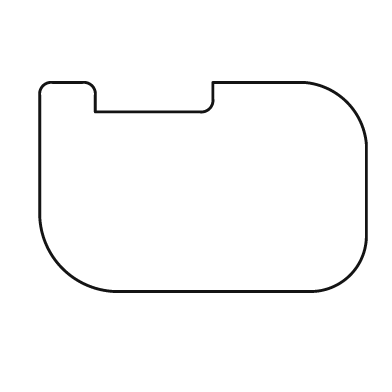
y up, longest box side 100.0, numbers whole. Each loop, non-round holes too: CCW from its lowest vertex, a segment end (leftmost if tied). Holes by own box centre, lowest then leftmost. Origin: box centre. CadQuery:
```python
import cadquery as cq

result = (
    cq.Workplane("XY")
    .moveTo(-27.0, -32.0)
    .lineTo(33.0, -32.0)
    .threePointArc((45.0, -27.0), (50.0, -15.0))
    .lineTo(50.0, 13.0)
    .threePointArc((44.0, 26.0), (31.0, 32.0))
    .lineTo(3.0, 32.0)
    .lineTo(3.0, 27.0)
    .threePointArc((2.0, 24.0), (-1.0, 23.0))
    .lineTo(-33.0, 23.0)
    .lineTo(-33.0, 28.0)
    .threePointArc((-34.0, 31.0), (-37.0, 32.0))
    .lineTo(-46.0, 32.0)
    .threePointArc((-49.0, 31.0), (-50.0, 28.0))
    .lineTo(-50.0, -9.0)
    .threePointArc((-43.0, -25.0), (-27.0, -32.0))
    .close()
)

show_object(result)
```